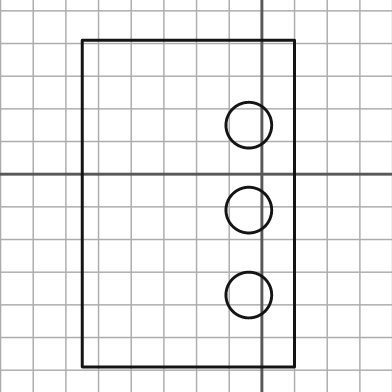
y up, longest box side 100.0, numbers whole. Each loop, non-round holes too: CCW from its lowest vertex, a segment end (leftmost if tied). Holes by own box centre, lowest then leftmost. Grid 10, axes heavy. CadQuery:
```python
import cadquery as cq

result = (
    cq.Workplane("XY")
    .moveTo(-55.0, -59.0)
    .lineTo(10.0, -59.0)
    .lineTo(10.0, 41.0)
    .lineTo(-55.0, 41.0)
    .close()
    .moveTo(-4.0, -37.0)
    .circle(7.0)
    .moveTo(-4.0, -11.0)
    .circle(7.0)
    .moveTo(-4.0, 15.0)
    .circle(7.0)
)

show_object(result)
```